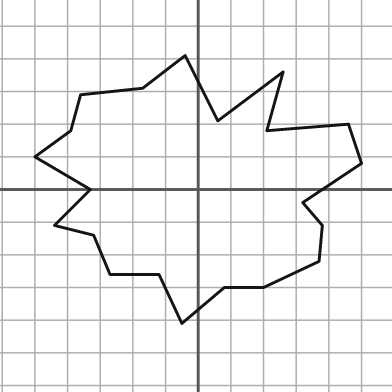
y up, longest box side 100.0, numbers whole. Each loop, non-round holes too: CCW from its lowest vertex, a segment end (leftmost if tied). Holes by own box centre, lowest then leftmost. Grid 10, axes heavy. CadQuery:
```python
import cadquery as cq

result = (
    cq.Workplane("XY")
    .moveTo(-5.0, -41.0)
    .lineTo(8.0, -30.0)
    .lineTo(20.0, -30.0)
    .lineTo(37.0, -22.0)
    .lineTo(38.0, -11.0)
    .lineTo(32.0, -4.0)
    .lineTo(50.0, 8.0)
    .lineTo(46.0, 20.0)
    .lineTo(21.0, 18.0)
    .lineTo(26.0, 36.0)
    .lineTo(6.0, 21.0)
    .lineTo(-4.0, 41.0)
    .lineTo(-17.0, 31.0)
    .lineTo(-36.0, 29.0)
    .lineTo(-39.0, 18.0)
    .lineTo(-50.0, 10.0)
    .lineTo(-33.0, 0.0)
    .lineTo(-44.0, -11.0)
    .lineTo(-32.0, -14.0)
    .lineTo(-27.0, -26.0)
    .lineTo(-12.0, -26.0)
    .close()
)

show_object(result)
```